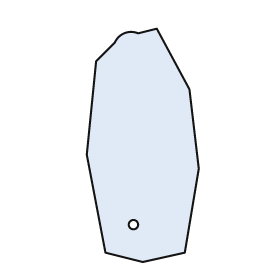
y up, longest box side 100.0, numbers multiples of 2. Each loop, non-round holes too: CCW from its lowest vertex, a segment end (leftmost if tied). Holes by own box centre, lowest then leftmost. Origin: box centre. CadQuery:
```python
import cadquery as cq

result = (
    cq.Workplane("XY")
    .moveTo(0.0, -50.0)
    .lineTo(18.0, -46.0)
    .lineTo(24.0, -10.0)
    .lineTo(20.0, 24.0)
    .lineTo(6.0, 50.0)
    .lineTo(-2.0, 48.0)
    .threePointArc((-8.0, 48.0), (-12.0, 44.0))
    .lineTo(-20.0, 36.0)
    .lineTo(-24.0, -4.0)
    .lineTo(-16.0, -46.0)
    .close()
    .moveTo(-4.0, -34.0)
    .circle(2.0)
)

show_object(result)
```